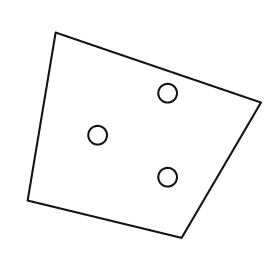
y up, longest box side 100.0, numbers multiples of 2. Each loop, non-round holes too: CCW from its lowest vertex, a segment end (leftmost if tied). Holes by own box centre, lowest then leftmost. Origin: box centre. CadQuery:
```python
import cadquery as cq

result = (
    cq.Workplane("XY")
    .moveTo(16.0, -44.0)
    .lineTo(50.0, 14.0)
    .lineTo(-38.0, 44.0)
    .lineTo(-50.0, -28.0)
    .close()
    .moveTo(10.0, -18.0)
    .circle(4.0)
    .moveTo(-20.0, 0.0)
    .circle(4.0)
    .moveTo(10.0, 18.0)
    .circle(4.0)
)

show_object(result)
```